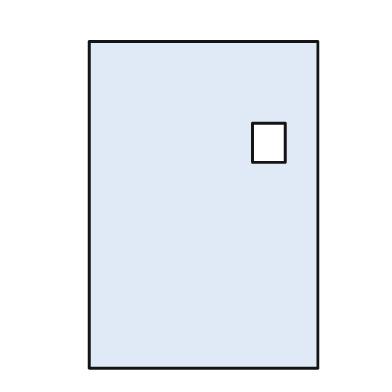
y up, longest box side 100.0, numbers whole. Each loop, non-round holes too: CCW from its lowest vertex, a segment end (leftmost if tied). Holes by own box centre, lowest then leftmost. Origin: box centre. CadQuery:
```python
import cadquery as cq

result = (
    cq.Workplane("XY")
    .moveTo(-35.0, -50.0)
    .lineTo(35.0, -50.0)
    .lineTo(35.0, 50.0)
    .lineTo(-35.0, 50.0)
    .close()
    .moveTo(15.0, 13.0)
    .lineTo(25.0, 13.0)
    .lineTo(25.0, 25.0)
    .lineTo(15.0, 25.0)
    .close()
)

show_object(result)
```